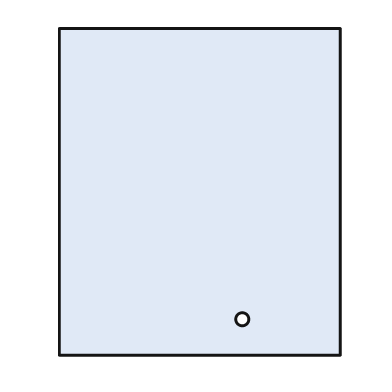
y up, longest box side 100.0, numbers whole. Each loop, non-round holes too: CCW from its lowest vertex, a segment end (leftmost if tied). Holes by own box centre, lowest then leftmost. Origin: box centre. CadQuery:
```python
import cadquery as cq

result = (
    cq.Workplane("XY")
    .moveTo(-43.0, -50.0)
    .lineTo(43.0, -50.0)
    .lineTo(43.0, 50.0)
    .lineTo(-43.0, 50.0)
    .close()
    .moveTo(13.0, -39.0)
    .circle(2.0)
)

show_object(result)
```